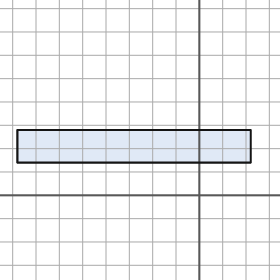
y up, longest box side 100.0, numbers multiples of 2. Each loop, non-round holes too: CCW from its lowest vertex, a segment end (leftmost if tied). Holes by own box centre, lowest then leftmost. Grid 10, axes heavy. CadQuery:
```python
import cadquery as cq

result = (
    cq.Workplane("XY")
    .moveTo(-78.0, 14.0)
    .lineTo(22.0, 14.0)
    .lineTo(22.0, 28.0)
    .lineTo(-78.0, 28.0)
    .close()
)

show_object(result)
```